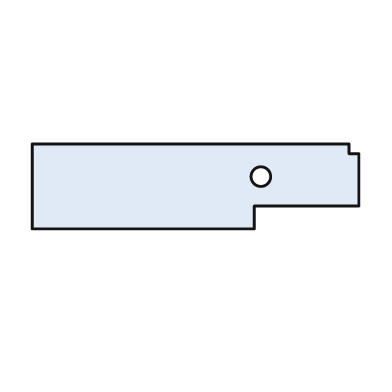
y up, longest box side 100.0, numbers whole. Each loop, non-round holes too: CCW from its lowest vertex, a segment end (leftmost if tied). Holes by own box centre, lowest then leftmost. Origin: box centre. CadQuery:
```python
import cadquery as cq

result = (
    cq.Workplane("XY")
    .moveTo(-50.0, -13.0)
    .lineTo(18.0, -13.0)
    .lineTo(18.0, -6.0)
    .lineTo(50.0, -6.0)
    .lineTo(50.0, 10.0)
    .lineTo(47.0, 10.0)
    .lineTo(47.0, 13.0)
    .lineTo(-50.0, 13.0)
    .close()
    .moveTo(20.0, 3.0)
    .circle(3.0)
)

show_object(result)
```